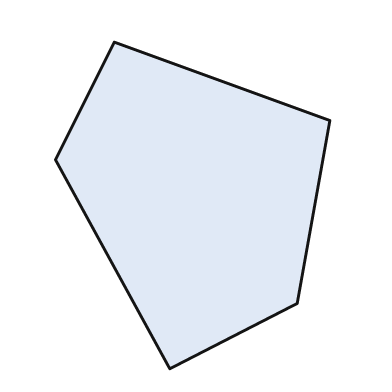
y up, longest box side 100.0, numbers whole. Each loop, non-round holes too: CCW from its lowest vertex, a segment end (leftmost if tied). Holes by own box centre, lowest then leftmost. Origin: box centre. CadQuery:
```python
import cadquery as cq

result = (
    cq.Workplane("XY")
    .moveTo(-7.0, -50.0)
    .lineTo(32.0, -30.0)
    .lineTo(42.0, 26.0)
    .lineTo(-24.0, 50.0)
    .lineTo(-42.0, 14.0)
    .close()
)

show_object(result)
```